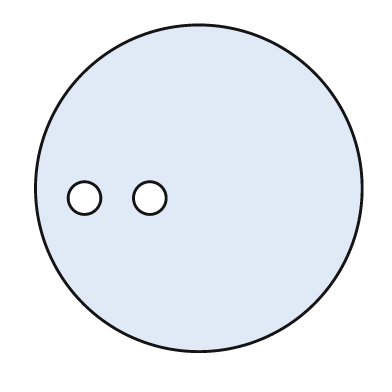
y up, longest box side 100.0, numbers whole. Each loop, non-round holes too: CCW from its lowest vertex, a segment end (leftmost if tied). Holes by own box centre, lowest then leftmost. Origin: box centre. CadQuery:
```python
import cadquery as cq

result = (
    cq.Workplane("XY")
    .moveTo(0.0, 0.0)
    .circle(50.0)
    .moveTo(-35.0, -3.0)
    .circle(5.0)
    .moveTo(-15.0, -3.0)
    .circle(5.0)
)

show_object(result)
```